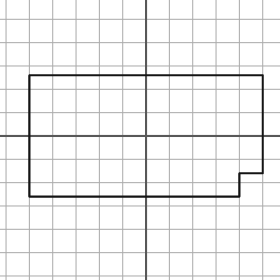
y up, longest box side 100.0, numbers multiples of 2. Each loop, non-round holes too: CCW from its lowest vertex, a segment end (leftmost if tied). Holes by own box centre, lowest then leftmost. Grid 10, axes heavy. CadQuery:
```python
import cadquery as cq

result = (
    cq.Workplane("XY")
    .moveTo(-50.0, -26.0)
    .lineTo(40.0, -26.0)
    .lineTo(40.0, -16.0)
    .lineTo(50.0, -16.0)
    .lineTo(50.0, 26.0)
    .lineTo(-50.0, 26.0)
    .close()
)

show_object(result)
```